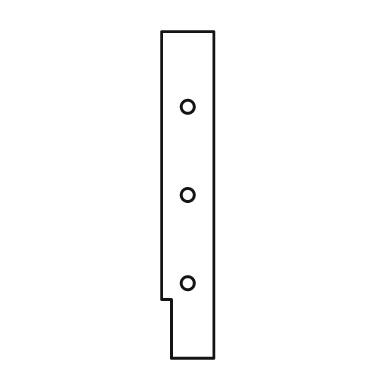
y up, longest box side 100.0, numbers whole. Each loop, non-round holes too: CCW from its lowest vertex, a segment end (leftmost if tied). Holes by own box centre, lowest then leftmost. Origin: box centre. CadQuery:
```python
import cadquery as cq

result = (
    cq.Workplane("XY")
    .moveTo(-5.0, -50.0)
    .lineTo(8.0, -50.0)
    .lineTo(8.0, 50.0)
    .lineTo(-8.0, 50.0)
    .lineTo(-8.0, -32.0)
    .lineTo(-5.0, -32.0)
    .close()
    .moveTo(0.0, -27.0)
    .circle(2.0)
    .moveTo(0.0, 0.0)
    .circle(2.0)
    .moveTo(0.0, 27.0)
    .circle(2.0)
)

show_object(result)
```